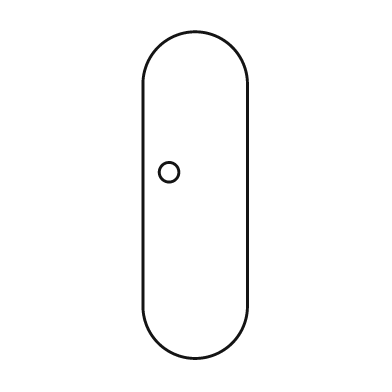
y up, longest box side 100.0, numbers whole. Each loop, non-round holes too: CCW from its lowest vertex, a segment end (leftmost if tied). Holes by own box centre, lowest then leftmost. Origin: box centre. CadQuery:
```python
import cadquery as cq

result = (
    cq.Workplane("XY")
    .moveTo(-16.0, -34.0)
    .threePointArc((0.0, -50.0), (16.0, -34.0))
    .lineTo(16.0, 34.0)
    .threePointArc((0.0, 50.0), (-16.0, 34.0))
    .close()
    .moveTo(-8.0, 7.0)
    .circle(3.0)
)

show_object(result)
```